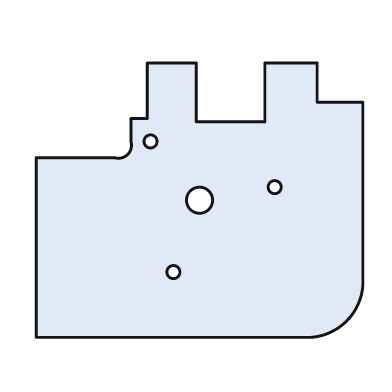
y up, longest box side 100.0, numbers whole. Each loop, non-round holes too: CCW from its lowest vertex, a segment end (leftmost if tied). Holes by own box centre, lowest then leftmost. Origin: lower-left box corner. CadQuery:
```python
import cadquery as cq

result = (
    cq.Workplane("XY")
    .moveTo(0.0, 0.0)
    .lineTo(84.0, 0.0)
    .threePointArc((95.0, 5.0), (100.0, 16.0))
    .lineTo(100.0, 72.0)
    .lineTo(86.0, 72.0)
    .lineTo(86.0, 84.0)
    .lineTo(70.0, 84.0)
    .lineTo(70.0, 66.0)
    .lineTo(49.0, 66.0)
    .lineTo(49.0, 84.0)
    .lineTo(34.0, 84.0)
    .lineTo(34.0, 67.0)
    .lineTo(29.0, 67.0)
    .lineTo(29.0, 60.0)
    .threePointArc((28.0, 56.0), (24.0, 55.0))
    .lineTo(0.0, 55.0)
    .close()
    .moveTo(42.0, 20.0)
    .circle(2.0)
    .moveTo(50.0, 42.0)
    .circle(4.0)
    .moveTo(73.0, 46.0)
    .circle(2.0)
    .moveTo(35.0, 60.0)
    .circle(2.0)
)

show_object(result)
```